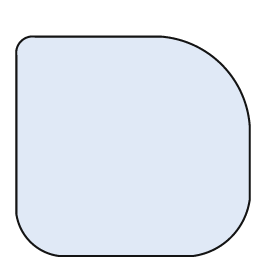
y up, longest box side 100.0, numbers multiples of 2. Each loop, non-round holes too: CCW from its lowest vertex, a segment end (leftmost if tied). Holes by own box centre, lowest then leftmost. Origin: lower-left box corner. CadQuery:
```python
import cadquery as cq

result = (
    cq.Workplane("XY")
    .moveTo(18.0, 0.0)
    .lineTo(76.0, 0.0)
    .threePointArc((92.0, 8.0), (100.0, 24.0))
    .lineTo(100.0, 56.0)
    .threePointArc((88.0, 82.0), (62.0, 94.0))
    .lineTo(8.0, 94.0)
    .threePointArc((2.0, 92.0), (0.0, 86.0))
    .lineTo(0.0, 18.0)
    .threePointArc((6.0, 6.0), (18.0, 0.0))
    .close()
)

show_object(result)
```